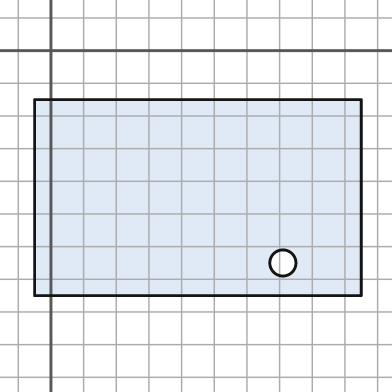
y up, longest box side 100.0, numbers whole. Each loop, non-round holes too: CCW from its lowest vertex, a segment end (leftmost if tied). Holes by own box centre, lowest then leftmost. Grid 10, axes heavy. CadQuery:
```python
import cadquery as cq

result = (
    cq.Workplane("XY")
    .moveTo(-5.0, -75.0)
    .lineTo(95.0, -75.0)
    .lineTo(95.0, -15.0)
    .lineTo(-5.0, -15.0)
    .close()
    .moveTo(71.0, -65.0)
    .circle(4.0)
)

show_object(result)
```